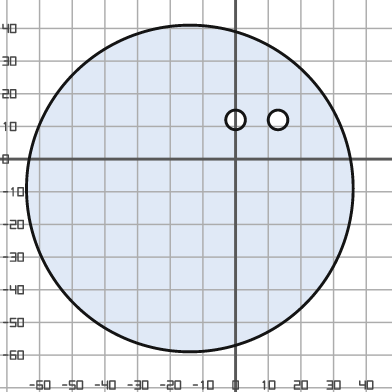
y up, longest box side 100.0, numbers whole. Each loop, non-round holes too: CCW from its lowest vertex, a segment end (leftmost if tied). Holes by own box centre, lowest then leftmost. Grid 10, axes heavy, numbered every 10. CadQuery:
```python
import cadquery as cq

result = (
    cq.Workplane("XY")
    .moveTo(-14.0, -9.0)
    .circle(50.0)
    .moveTo(0.0, 12.0)
    .circle(3.0)
    .moveTo(13.0, 12.0)
    .circle(3.0)
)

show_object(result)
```